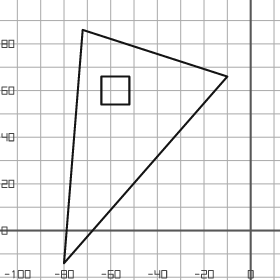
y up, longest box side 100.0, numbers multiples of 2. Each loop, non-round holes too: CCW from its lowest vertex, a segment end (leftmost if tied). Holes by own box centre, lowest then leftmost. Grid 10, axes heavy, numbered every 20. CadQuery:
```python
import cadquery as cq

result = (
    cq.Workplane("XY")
    .moveTo(-80.0, -14.0)
    .lineTo(-10.0, 66.0)
    .lineTo(-72.0, 86.0)
    .close()
    .moveTo(-64.0, 54.0)
    .lineTo(-52.0, 54.0)
    .lineTo(-52.0, 66.0)
    .lineTo(-64.0, 66.0)
    .close()
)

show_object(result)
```